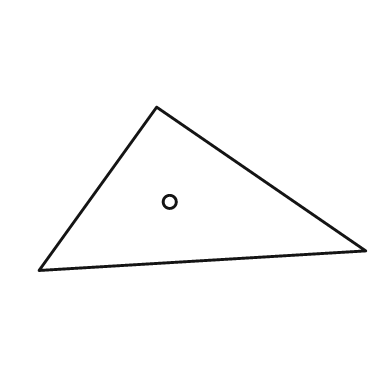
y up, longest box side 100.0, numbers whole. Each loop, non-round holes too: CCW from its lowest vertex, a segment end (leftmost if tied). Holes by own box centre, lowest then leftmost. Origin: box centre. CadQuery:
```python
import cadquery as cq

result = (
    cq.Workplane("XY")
    .moveTo(-50.0, -25.0)
    .lineTo(50.0, -19.0)
    .lineTo(-14.0, 25.0)
    .close()
    .moveTo(-10.0, -4.0)
    .circle(2.0)
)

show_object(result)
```